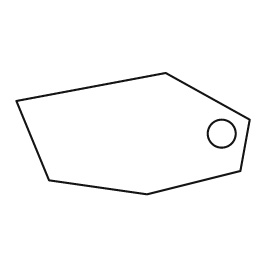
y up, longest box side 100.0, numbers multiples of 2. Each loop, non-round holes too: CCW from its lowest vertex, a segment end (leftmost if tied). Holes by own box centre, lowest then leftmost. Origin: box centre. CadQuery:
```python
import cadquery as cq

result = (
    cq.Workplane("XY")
    .moveTo(6.0, -26.0)
    .lineTo(46.0, -16.0)
    .lineTo(50.0, 6.0)
    .lineTo(14.0, 26.0)
    .lineTo(-50.0, 14.0)
    .lineTo(-36.0, -20.0)
    .close()
    .moveTo(38.0, 0.0)
    .circle(6.0)
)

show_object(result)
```